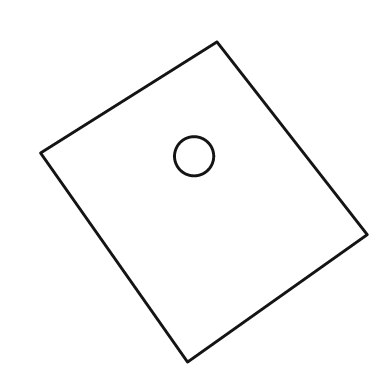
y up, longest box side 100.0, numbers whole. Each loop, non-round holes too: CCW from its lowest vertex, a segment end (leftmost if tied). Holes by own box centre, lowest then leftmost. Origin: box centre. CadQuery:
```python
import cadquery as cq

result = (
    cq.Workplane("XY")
    .moveTo(-5.0, -49.0)
    .lineTo(50.0, -10.0)
    .lineTo(4.0, 49.0)
    .lineTo(-50.0, 15.0)
    .close()
    .moveTo(-3.0, 14.0)
    .circle(6.0)
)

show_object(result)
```